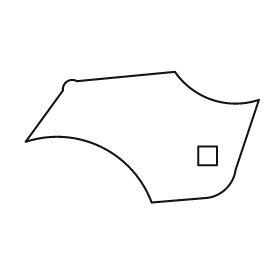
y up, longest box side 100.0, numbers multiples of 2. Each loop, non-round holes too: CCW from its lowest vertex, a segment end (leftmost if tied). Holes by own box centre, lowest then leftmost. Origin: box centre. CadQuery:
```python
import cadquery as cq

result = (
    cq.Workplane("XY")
    .moveTo(4.0, -28.0)
    .lineTo(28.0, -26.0)
    .threePointArc((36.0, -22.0), (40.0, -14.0))
    .lineTo(50.0, 16.0)
    .threePointArc((30.0, 16.0), (14.0, 28.0))
    .lineTo(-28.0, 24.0)
    .threePointArc((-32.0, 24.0), (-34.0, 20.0))
    .lineTo(-50.0, -2.0)
    .threePointArc((-18.0, -4.0), (4.0, -28.0))
    .close()
    .moveTo(24.0, -12.0)
    .lineTo(32.0, -12.0)
    .lineTo(32.0, -4.0)
    .lineTo(24.0, -4.0)
    .close()
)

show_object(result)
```